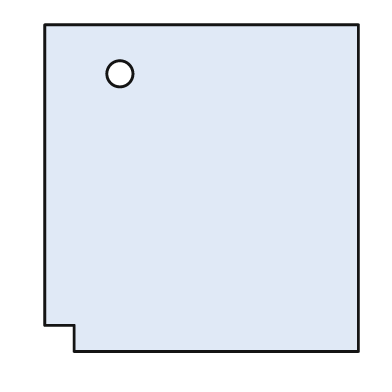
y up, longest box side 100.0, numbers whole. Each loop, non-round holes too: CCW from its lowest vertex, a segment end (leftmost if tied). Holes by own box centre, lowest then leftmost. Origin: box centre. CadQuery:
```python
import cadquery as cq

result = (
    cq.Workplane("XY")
    .moveTo(-39.0, -50.0)
    .lineTo(48.0, -50.0)
    .lineTo(48.0, 50.0)
    .lineTo(-48.0, 50.0)
    .lineTo(-48.0, -42.0)
    .lineTo(-39.0, -42.0)
    .close()
    .moveTo(-25.0, 35.0)
    .circle(4.0)
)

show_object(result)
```